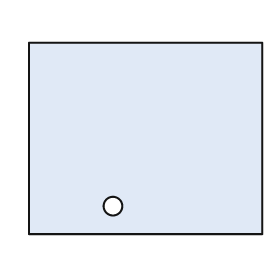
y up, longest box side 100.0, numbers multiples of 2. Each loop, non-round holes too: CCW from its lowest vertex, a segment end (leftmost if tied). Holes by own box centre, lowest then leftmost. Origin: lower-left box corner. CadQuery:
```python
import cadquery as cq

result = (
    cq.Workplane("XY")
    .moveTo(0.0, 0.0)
    .lineTo(100.0, 0.0)
    .lineTo(100.0, 82.0)
    .lineTo(0.0, 82.0)
    .close()
    .moveTo(36.0, 12.0)
    .circle(4.0)
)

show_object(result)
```